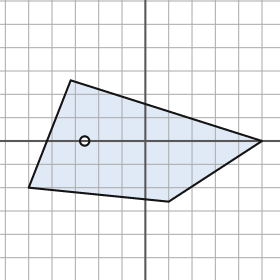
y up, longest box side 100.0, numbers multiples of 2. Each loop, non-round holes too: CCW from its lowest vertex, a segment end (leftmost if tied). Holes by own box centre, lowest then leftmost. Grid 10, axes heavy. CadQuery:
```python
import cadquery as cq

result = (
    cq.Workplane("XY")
    .moveTo(10.0, -26.0)
    .lineTo(50.0, 0.0)
    .lineTo(-32.0, 26.0)
    .lineTo(-50.0, -20.0)
    .close()
    .moveTo(-26.0, 0.0)
    .circle(2.0)
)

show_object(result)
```